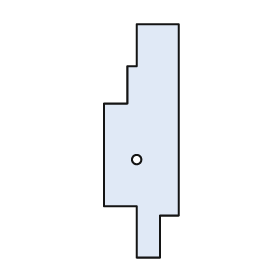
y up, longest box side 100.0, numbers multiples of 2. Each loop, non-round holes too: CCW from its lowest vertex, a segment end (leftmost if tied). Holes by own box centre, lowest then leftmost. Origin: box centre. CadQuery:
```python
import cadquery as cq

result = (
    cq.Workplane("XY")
    .moveTo(-2.0, -50.0)
    .lineTo(8.0, -50.0)
    .lineTo(8.0, -32.0)
    .lineTo(16.0, -32.0)
    .lineTo(16.0, 50.0)
    .lineTo(-2.0, 50.0)
    .lineTo(-2.0, 32.0)
    .lineTo(-6.0, 32.0)
    .lineTo(-6.0, 16.0)
    .lineTo(-16.0, 16.0)
    .lineTo(-16.0, -28.0)
    .lineTo(-2.0, -28.0)
    .close()
    .moveTo(-2.0, -8.0)
    .circle(2.0)
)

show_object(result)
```